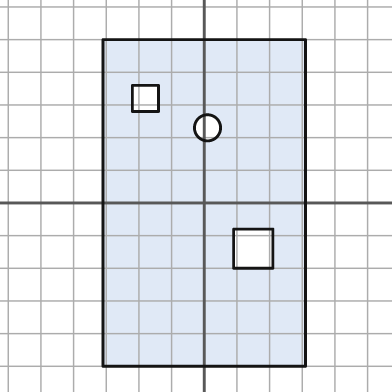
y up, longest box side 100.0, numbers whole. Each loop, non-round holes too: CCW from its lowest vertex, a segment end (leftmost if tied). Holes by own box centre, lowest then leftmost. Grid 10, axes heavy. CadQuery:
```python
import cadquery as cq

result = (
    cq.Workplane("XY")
    .moveTo(-31.0, -50.0)
    .lineTo(31.0, -50.0)
    .lineTo(31.0, 50.0)
    .lineTo(-31.0, 50.0)
    .close()
    .moveTo(9.0, -20.0)
    .lineTo(21.0, -20.0)
    .lineTo(21.0, -8.0)
    .lineTo(9.0, -8.0)
    .close()
    .moveTo(1.0, 23.0)
    .circle(4.0)
    .moveTo(-22.0, 28.0)
    .lineTo(-14.0, 28.0)
    .lineTo(-14.0, 36.0)
    .lineTo(-22.0, 36.0)
    .close()
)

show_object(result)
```